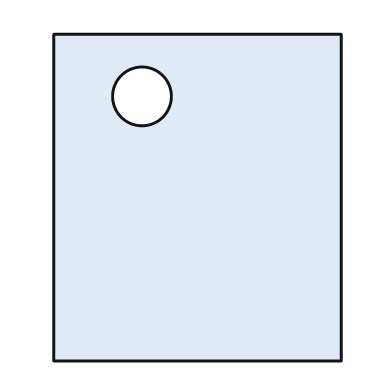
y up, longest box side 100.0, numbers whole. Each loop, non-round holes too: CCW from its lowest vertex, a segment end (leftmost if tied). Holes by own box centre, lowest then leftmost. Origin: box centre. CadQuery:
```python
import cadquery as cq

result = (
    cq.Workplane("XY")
    .moveTo(-44.0, -50.0)
    .lineTo(44.0, -50.0)
    .lineTo(44.0, 50.0)
    .lineTo(-44.0, 50.0)
    .close()
    .moveTo(-17.0, 31.0)
    .circle(9.0)
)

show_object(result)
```